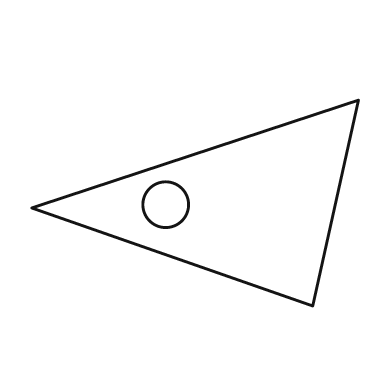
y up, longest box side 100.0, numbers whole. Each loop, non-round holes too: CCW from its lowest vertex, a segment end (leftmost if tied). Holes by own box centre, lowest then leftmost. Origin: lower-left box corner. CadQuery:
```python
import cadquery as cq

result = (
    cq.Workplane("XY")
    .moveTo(86.0, 0.0)
    .lineTo(100.0, 63.0)
    .lineTo(0.0, 30.0)
    .close()
    .moveTo(41.0, 31.0)
    .circle(7.0)
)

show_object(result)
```